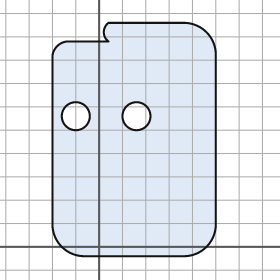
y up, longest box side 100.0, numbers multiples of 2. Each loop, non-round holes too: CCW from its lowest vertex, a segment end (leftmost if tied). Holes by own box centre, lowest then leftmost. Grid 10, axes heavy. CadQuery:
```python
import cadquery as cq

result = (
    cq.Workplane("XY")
    .moveTo(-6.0, -4.0)
    .lineTo(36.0, -4.0)
    .threePointArc((46.0, 0.0), (50.0, 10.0))
    .lineTo(50.0, 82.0)
    .threePointArc((46.0, 92.0), (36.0, 96.0))
    .lineTo(4.0, 96.0)
    .threePointArc((2.0, 92.0), (4.0, 88.0))
    .lineTo(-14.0, 88.0)
    .threePointArc((-18.0, 86.0), (-20.0, 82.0))
    .lineTo(-20.0, 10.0)
    .threePointArc((-16.0, 0.0), (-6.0, -4.0))
    .close()
    .moveTo(-10.0, 56.0)
    .circle(6.0)
    .moveTo(16.0, 56.0)
    .circle(6.0)
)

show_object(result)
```